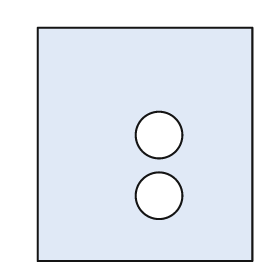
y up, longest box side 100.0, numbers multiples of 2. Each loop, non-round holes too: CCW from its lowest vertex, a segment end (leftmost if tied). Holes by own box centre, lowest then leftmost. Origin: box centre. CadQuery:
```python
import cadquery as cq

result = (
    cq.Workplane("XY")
    .moveTo(-46.0, -50.0)
    .lineTo(46.0, -50.0)
    .lineTo(46.0, 50.0)
    .lineTo(-46.0, 50.0)
    .close()
    .moveTo(6.0, -22.0)
    .circle(10.0)
    .moveTo(6.0, 4.0)
    .circle(10.0)
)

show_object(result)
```